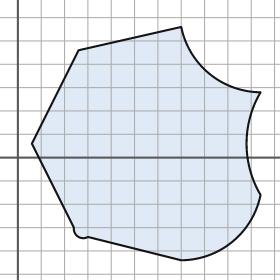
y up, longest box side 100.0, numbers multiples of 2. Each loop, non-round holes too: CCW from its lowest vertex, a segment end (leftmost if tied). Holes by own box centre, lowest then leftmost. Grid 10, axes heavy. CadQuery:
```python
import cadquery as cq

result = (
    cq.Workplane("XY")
    .moveTo(70.0, -44.0)
    .threePointArc((92.0, -36.0), (104.0, -16.0))
    .threePointArc((98.0, 6.0), (104.0, 28.0))
    .threePointArc((82.0, 36.0), (70.0, 56.0))
    .lineTo(26.0, 46.0)
    .lineTo(6.0, 6.0)
    .lineTo(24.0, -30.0)
    .threePointArc((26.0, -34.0), (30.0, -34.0))
    .close()
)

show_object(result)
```